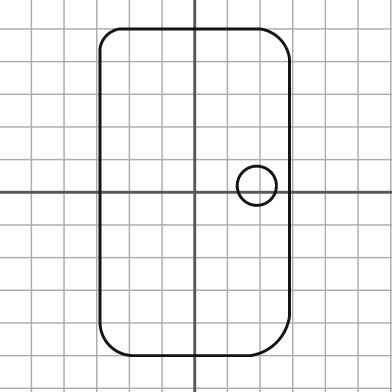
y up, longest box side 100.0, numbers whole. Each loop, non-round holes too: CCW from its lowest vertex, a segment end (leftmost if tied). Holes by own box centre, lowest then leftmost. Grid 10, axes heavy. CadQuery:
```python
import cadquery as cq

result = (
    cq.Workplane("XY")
    .moveTo(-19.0, -50.0)
    .lineTo(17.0, -50.0)
    .threePointArc((25.0, -46.0), (29.0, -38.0))
    .lineTo(29.0, 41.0)
    .threePointArc((26.0, 47.0), (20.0, 50.0))
    .lineTo(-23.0, 50.0)
    .threePointArc((-27.0, 48.0), (-29.0, 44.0))
    .lineTo(-29.0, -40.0)
    .threePointArc((-26.0, -47.0), (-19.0, -50.0))
    .close()
    .moveTo(19.0, 2.0)
    .circle(6.0)
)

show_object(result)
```